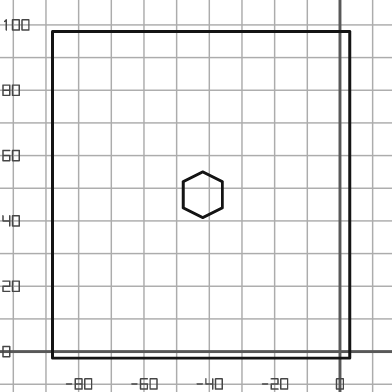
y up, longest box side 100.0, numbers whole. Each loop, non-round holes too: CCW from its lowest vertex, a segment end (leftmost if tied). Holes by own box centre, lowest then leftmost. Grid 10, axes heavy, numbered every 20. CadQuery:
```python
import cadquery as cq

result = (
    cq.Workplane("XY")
    .moveTo(-88.0, -2.0)
    .lineTo(3.0, -2.0)
    .lineTo(3.0, 98.0)
    .lineTo(-88.0, 98.0)
    .close()
    .moveTo(-42.0, 41.0)
    .lineTo(-36.0, 44.0)
    .lineTo(-36.0, 52.0)
    .lineTo(-42.0, 55.0)
    .lineTo(-48.0, 52.0)
    .lineTo(-48.0, 44.0)
    .close()
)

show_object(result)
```